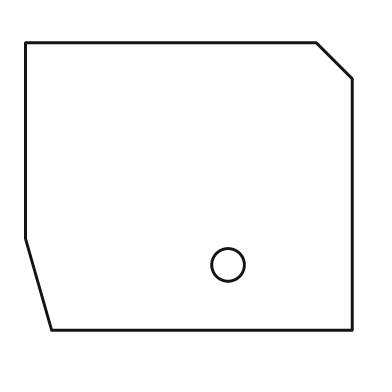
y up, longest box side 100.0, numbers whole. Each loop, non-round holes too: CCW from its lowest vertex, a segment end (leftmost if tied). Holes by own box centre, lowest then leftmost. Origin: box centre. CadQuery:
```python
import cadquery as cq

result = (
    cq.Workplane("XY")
    .moveTo(-42.0, -44.0)
    .lineTo(50.0, -44.0)
    .lineTo(50.0, 33.0)
    .lineTo(39.0, 44.0)
    .lineTo(-50.0, 44.0)
    .lineTo(-50.0, -16.0)
    .close()
    .moveTo(12.0, -24.0)
    .circle(5.0)
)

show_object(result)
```